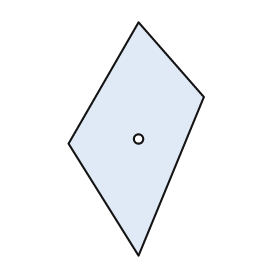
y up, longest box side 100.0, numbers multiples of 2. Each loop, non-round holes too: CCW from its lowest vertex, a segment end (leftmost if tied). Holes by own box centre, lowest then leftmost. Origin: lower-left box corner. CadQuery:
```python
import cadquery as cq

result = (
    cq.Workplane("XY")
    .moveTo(30.0, 0.0)
    .lineTo(58.0, 68.0)
    .lineTo(30.0, 100.0)
    .lineTo(0.0, 48.0)
    .close()
    .moveTo(30.0, 50.0)
    .circle(2.0)
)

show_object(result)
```